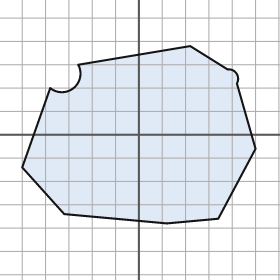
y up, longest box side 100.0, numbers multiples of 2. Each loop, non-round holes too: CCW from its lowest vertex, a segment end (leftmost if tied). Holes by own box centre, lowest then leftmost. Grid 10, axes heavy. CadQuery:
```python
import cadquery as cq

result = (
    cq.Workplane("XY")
    .moveTo(12.0, -38.0)
    .lineTo(34.0, -36.0)
    .lineTo(50.0, -6.0)
    .lineTo(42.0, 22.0)
    .threePointArc((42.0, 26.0), (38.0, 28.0))
    .lineTo(22.0, 38.0)
    .lineTo(-26.0, 30.0)
    .threePointArc((-28.0, 20.0), (-38.0, 20.0))
    .lineTo(-50.0, -14.0)
    .lineTo(-32.0, -34.0)
    .close()
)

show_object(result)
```